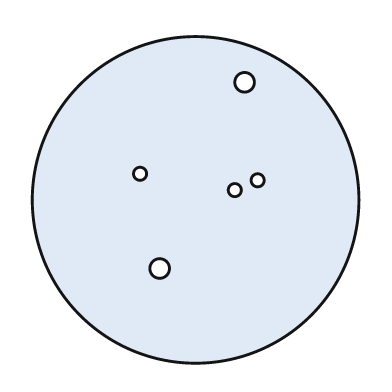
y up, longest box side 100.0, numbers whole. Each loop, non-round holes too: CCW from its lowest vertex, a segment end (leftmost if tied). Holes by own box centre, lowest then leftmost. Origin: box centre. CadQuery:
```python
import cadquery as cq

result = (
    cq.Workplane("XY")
    .moveTo(0.0, 0.0)
    .circle(50.0)
    .moveTo(-11.0, -21.0)
    .circle(3.0)
    .moveTo(12.0, 3.0)
    .circle(2.0)
    .moveTo(19.0, 6.0)
    .circle(2.0)
    .moveTo(-17.0, 8.0)
    .circle(2.0)
    .moveTo(15.0, 36.0)
    .circle(3.0)
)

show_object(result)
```